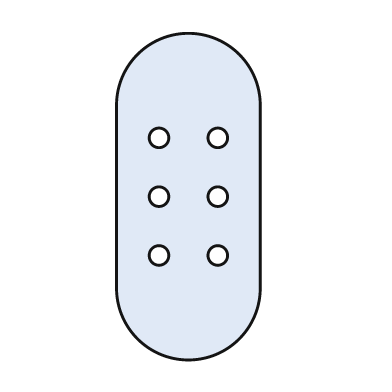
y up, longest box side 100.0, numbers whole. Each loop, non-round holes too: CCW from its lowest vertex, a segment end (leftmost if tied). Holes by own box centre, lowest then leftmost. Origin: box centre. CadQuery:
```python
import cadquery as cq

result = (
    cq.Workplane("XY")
    .moveTo(-22.0, -28.0)
    .threePointArc((0.0, -50.0), (22.0, -28.0))
    .lineTo(22.0, 28.0)
    .threePointArc((0.0, 50.0), (-22.0, 28.0))
    .close()
    .moveTo(-9.0, -18.0)
    .circle(3.0)
    .moveTo(9.0, -18.0)
    .circle(3.0)
    .moveTo(-9.0, 0.0)
    .circle(3.0)
    .moveTo(9.0, 0.0)
    .circle(3.0)
    .moveTo(-9.0, 18.0)
    .circle(3.0)
    .moveTo(9.0, 18.0)
    .circle(3.0)
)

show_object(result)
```